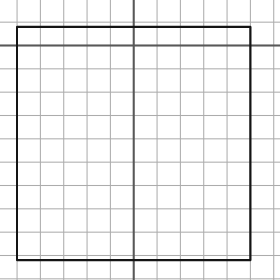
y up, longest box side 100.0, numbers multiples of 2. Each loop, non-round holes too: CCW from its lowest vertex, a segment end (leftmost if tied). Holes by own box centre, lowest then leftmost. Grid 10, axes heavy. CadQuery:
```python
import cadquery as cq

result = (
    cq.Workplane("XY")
    .moveTo(-50.0, -92.0)
    .lineTo(50.0, -92.0)
    .lineTo(50.0, 8.0)
    .lineTo(-50.0, 8.0)
    .close()
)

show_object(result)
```